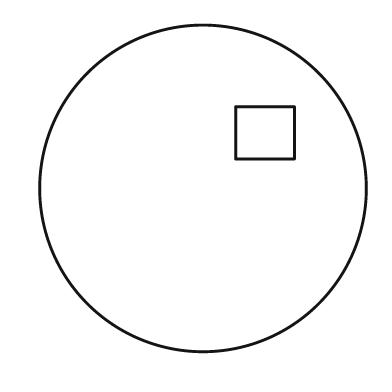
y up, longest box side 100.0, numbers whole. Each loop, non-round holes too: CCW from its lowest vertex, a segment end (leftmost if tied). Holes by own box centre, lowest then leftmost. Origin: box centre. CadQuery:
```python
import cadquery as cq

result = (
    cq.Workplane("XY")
    .moveTo(0.0, 0.0)
    .circle(50.0)
    .moveTo(10.0, 9.0)
    .lineTo(28.0, 9.0)
    .lineTo(28.0, 25.0)
    .lineTo(10.0, 25.0)
    .close()
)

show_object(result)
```